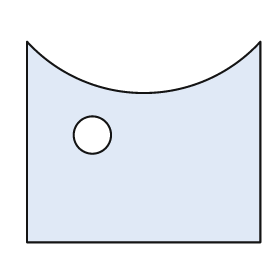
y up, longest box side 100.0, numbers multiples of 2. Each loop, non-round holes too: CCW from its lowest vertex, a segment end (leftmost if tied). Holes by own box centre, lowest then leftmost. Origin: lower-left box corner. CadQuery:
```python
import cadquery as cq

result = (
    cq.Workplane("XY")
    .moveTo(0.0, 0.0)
    .lineTo(100.0, 0.0)
    .lineTo(100.0, 86.0)
    .threePointArc((50.0, 64.0), (0.0, 86.0))
    .close()
    .moveTo(28.0, 46.0)
    .circle(8.0)
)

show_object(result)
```